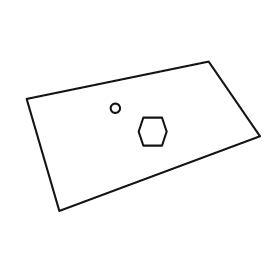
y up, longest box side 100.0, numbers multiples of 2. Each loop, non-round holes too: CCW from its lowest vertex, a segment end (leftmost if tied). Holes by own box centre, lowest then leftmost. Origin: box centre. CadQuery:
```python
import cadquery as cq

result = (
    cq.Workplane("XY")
    .moveTo(-36.0, -32.0)
    .lineTo(50.0, 0.0)
    .lineTo(28.0, 32.0)
    .lineTo(-50.0, 16.0)
    .close()
    .moveTo(0.0, -4.0)
    .lineTo(8.0, -4.0)
    .lineTo(10.0, 2.0)
    .lineTo(8.0, 8.0)
    .lineTo(0.0, 8.0)
    .lineTo(-2.0, 2.0)
    .close()
    .moveTo(-12.0, 12.0)
    .circle(2.0)
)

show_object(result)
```